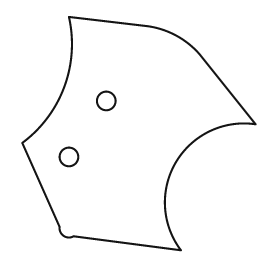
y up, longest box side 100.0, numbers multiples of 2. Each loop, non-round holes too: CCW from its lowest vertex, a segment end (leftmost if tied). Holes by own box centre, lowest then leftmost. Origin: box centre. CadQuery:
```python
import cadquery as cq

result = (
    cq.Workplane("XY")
    .moveTo(18.0, -50.0)
    .threePointArc((16.0, -12.0), (50.0, 4.0))
    .lineTo(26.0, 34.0)
    .threePointArc((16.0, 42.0), (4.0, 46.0))
    .lineTo(-30.0, 50.0)
    .threePointArc((-32.0, 20.0), (-50.0, -4.0))
    .lineTo(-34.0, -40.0)
    .threePointArc((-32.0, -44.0), (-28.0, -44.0))
    .close()
    .moveTo(-30.0, -10.0)
    .circle(4.0)
    .moveTo(-14.0, 14.0)
    .circle(4.0)
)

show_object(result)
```